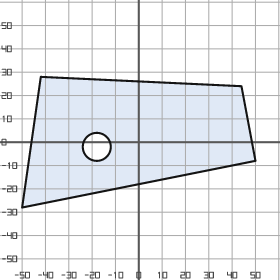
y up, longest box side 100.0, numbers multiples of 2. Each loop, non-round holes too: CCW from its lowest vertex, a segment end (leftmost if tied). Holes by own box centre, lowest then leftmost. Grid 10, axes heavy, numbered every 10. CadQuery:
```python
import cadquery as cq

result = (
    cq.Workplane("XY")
    .moveTo(-50.0, -28.0)
    .lineTo(50.0, -8.0)
    .lineTo(44.0, 24.0)
    .lineTo(-42.0, 28.0)
    .close()
    .moveTo(-18.0, -2.0)
    .circle(6.0)
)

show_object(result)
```